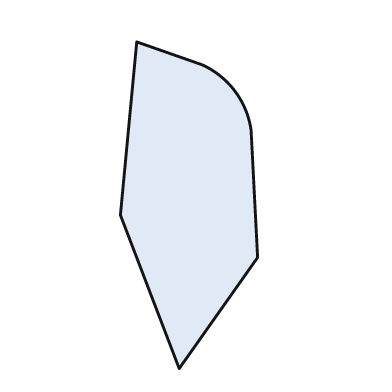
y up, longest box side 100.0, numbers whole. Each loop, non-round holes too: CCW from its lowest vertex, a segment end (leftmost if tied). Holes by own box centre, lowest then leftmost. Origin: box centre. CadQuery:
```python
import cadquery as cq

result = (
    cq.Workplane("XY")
    .moveTo(-3.0, -50.0)
    .lineTo(21.0, -16.0)
    .lineTo(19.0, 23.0)
    .threePointArc((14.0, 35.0), (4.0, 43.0))
    .lineTo(-16.0, 50.0)
    .lineTo(-21.0, -3.0)
    .close()
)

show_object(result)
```